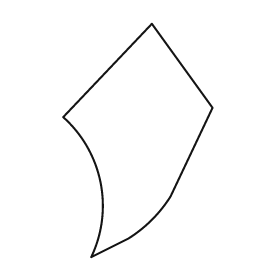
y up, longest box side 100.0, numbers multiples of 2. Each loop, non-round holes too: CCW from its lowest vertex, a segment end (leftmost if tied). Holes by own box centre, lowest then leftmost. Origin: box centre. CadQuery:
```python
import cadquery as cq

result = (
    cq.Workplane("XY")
    .moveTo(-20.0, -50.0)
    .lineTo(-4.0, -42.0)
    .threePointArc((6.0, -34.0), (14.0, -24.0))
    .lineTo(32.0, 14.0)
    .lineTo(6.0, 50.0)
    .lineTo(-32.0, 10.0)
    .threePointArc((-16.0, -18.0), (-20.0, -50.0))
    .close()
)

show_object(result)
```